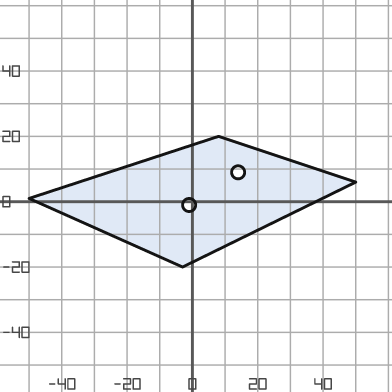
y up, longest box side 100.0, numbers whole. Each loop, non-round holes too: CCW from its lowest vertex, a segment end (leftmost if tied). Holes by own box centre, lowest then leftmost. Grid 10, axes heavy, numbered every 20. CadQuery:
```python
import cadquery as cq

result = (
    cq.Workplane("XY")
    .moveTo(-3.0, -20.0)
    .lineTo(50.0, 6.0)
    .lineTo(8.0, 20.0)
    .lineTo(-50.0, 1.0)
    .close()
    .moveTo(-1.0, -1.0)
    .circle(2.0)
    .moveTo(14.0, 9.0)
    .circle(2.0)
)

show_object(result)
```